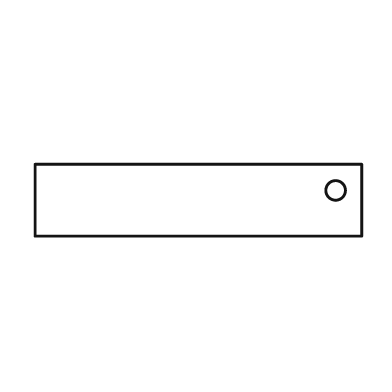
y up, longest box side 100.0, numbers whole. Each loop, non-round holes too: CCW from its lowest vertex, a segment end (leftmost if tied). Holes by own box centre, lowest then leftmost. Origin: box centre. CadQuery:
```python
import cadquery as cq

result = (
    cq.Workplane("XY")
    .moveTo(-50.0, -11.0)
    .lineTo(50.0, -11.0)
    .lineTo(50.0, 11.0)
    .lineTo(-50.0, 11.0)
    .close()
    .moveTo(42.0, 3.0)
    .circle(3.0)
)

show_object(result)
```